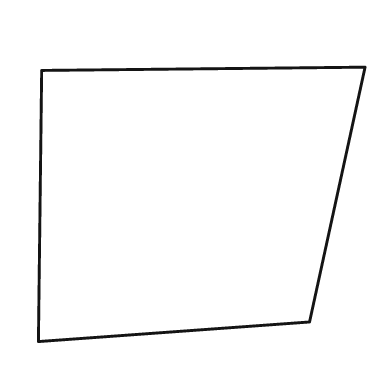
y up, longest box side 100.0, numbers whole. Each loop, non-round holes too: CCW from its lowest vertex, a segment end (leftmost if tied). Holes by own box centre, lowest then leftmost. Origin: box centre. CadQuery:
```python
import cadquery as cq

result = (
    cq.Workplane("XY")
    .moveTo(-50.0, -42.0)
    .lineTo(33.0, -36.0)
    .lineTo(50.0, 42.0)
    .lineTo(-49.0, 41.0)
    .close()
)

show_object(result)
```